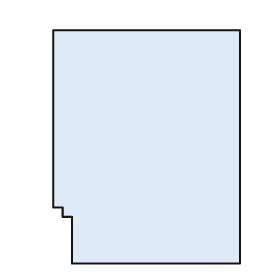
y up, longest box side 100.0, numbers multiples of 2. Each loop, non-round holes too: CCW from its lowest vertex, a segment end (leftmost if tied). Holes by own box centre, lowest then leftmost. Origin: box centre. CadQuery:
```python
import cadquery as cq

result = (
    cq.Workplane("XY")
    .moveTo(-32.0, -50.0)
    .lineTo(40.0, -50.0)
    .lineTo(40.0, 50.0)
    .lineTo(-40.0, 50.0)
    .lineTo(-40.0, -26.0)
    .lineTo(-36.0, -26.0)
    .lineTo(-36.0, -30.0)
    .lineTo(-32.0, -30.0)
    .close()
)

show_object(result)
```